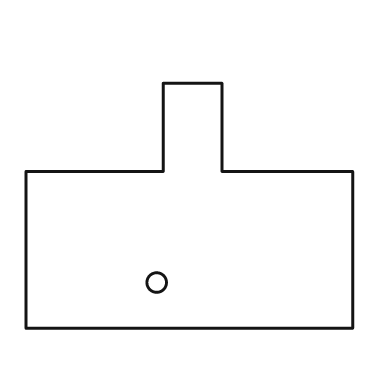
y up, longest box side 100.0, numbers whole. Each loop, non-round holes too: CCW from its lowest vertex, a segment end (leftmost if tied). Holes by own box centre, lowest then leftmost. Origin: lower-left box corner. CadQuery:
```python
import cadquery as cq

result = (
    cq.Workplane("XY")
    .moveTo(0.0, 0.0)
    .lineTo(100.0, 0.0)
    .lineTo(100.0, 48.0)
    .lineTo(60.0, 48.0)
    .lineTo(60.0, 75.0)
    .lineTo(42.0, 75.0)
    .lineTo(42.0, 48.0)
    .lineTo(0.0, 48.0)
    .close()
    .moveTo(40.0, 14.0)
    .circle(3.0)
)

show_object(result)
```